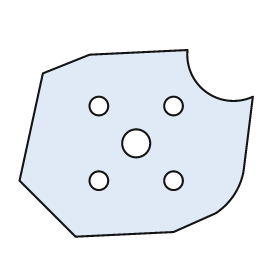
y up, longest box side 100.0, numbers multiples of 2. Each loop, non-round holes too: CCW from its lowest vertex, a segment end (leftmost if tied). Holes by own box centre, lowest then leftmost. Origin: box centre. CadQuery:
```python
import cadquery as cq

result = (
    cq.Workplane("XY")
    .moveTo(-26.0, -40.0)
    .lineTo(16.0, -38.0)
    .lineTo(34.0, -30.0)
    .threePointArc((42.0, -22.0), (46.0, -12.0))
    .lineTo(50.0, 20.0)
    .threePointArc((30.0, 22.0), (22.0, 40.0))
    .lineTo(-20.0, 38.0)
    .lineTo(-40.0, 30.0)
    .lineTo(-50.0, -16.0)
    .close()
    .moveTo(-16.0, -16.0)
    .circle(4.0)
    .moveTo(16.0, -16.0)
    .circle(4.0)
    .moveTo(0.0, 0.0)
    .circle(6.0)
    .moveTo(-16.0, 16.0)
    .circle(4.0)
    .moveTo(16.0, 16.0)
    .circle(4.0)
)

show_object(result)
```